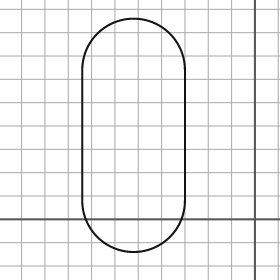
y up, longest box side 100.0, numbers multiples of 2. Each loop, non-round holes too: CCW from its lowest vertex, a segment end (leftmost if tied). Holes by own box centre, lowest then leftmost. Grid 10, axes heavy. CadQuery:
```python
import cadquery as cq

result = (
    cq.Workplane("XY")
    .moveTo(-74.0, 8.0)
    .threePointArc((-52.0, -14.0), (-30.0, 8.0))
    .lineTo(-30.0, 64.0)
    .threePointArc((-52.0, 86.0), (-74.0, 64.0))
    .close()
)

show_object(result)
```